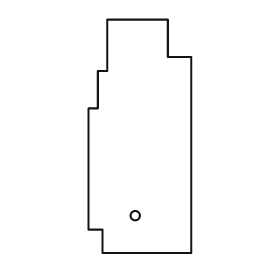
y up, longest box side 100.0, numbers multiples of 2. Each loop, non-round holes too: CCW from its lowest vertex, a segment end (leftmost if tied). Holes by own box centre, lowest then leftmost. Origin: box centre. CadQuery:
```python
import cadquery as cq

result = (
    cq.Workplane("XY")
    .moveTo(-16.0, -50.0)
    .lineTo(22.0, -50.0)
    .lineTo(22.0, 34.0)
    .lineTo(12.0, 34.0)
    .lineTo(12.0, 50.0)
    .lineTo(-14.0, 50.0)
    .lineTo(-14.0, 28.0)
    .lineTo(-18.0, 28.0)
    .lineTo(-18.0, 12.0)
    .lineTo(-22.0, 12.0)
    .lineTo(-22.0, -40.0)
    .lineTo(-16.0, -40.0)
    .close()
    .moveTo(-2.0, -34.0)
    .circle(2.0)
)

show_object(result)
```